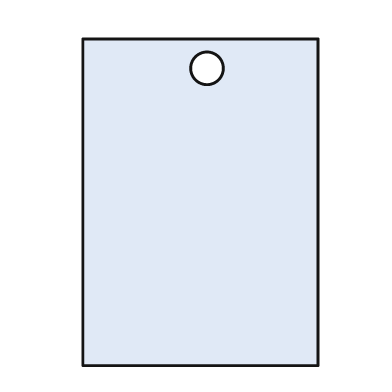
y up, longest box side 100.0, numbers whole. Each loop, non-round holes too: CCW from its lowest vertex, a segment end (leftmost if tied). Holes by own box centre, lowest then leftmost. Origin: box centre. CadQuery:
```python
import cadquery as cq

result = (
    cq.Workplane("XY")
    .moveTo(-36.0, -50.0)
    .lineTo(36.0, -50.0)
    .lineTo(36.0, 50.0)
    .lineTo(-36.0, 50.0)
    .close()
    .moveTo(2.0, 41.0)
    .circle(5.0)
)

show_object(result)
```